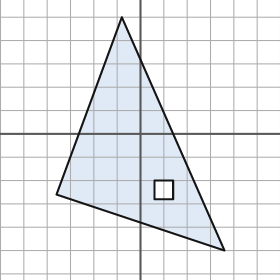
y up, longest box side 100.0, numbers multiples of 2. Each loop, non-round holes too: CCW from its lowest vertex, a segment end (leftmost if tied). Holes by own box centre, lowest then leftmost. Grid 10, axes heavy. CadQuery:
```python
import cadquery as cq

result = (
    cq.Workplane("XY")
    .moveTo(36.0, -50.0)
    .lineTo(-8.0, 50.0)
    .lineTo(-36.0, -26.0)
    .close()
    .moveTo(6.0, -28.0)
    .lineTo(14.0, -28.0)
    .lineTo(14.0, -20.0)
    .lineTo(6.0, -20.0)
    .close()
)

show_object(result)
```